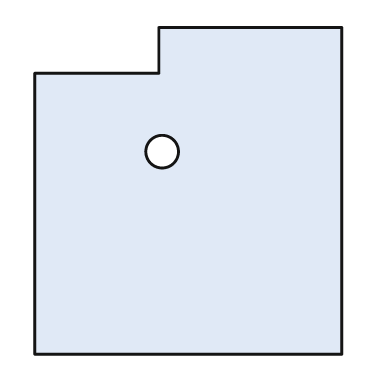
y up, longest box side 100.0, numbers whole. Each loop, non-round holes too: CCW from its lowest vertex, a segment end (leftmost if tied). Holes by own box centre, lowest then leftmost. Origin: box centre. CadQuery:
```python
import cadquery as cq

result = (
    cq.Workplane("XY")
    .moveTo(-47.0, -50.0)
    .lineTo(47.0, -50.0)
    .lineTo(47.0, 50.0)
    .lineTo(-9.0, 50.0)
    .lineTo(-9.0, 36.0)
    .lineTo(-47.0, 36.0)
    .close()
    .moveTo(-8.0, 12.0)
    .circle(5.0)
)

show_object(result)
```